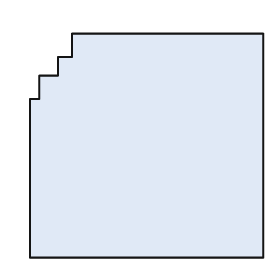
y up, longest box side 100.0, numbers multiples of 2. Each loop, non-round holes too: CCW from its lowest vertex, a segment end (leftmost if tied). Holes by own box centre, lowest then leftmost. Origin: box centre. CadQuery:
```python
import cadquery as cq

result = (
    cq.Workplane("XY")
    .moveTo(-50.0, -48.0)
    .lineTo(50.0, -48.0)
    .lineTo(50.0, 48.0)
    .lineTo(-32.0, 48.0)
    .lineTo(-32.0, 38.0)
    .lineTo(-38.0, 38.0)
    .lineTo(-38.0, 30.0)
    .lineTo(-46.0, 30.0)
    .lineTo(-46.0, 20.0)
    .lineTo(-50.0, 20.0)
    .close()
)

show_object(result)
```